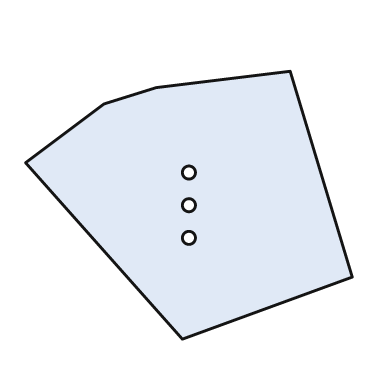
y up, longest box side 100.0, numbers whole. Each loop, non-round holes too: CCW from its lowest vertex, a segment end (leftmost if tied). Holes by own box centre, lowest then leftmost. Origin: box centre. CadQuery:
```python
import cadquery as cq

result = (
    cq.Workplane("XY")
    .moveTo(-2.0, -41.0)
    .lineTo(50.0, -22.0)
    .lineTo(31.0, 41.0)
    .lineTo(-10.0, 36.0)
    .lineTo(-26.0, 31.0)
    .lineTo(-50.0, 13.0)
    .close()
    .moveTo(0.0, -10.0)
    .circle(2.0)
    .moveTo(0.0, 0.0)
    .circle(2.0)
    .moveTo(0.0, 10.0)
    .circle(2.0)
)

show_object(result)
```